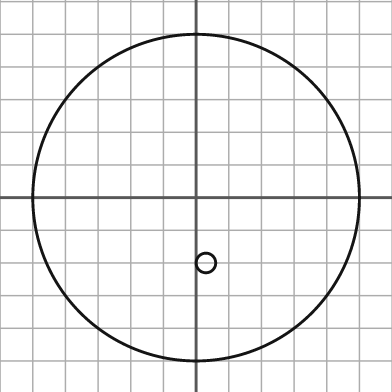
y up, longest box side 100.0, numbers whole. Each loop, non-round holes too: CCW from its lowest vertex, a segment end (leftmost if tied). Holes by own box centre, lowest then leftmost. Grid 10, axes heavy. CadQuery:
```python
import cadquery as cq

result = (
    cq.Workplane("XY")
    .moveTo(0.0, 0.0)
    .circle(50.0)
    .moveTo(3.0, -20.0)
    .circle(3.0)
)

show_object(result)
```